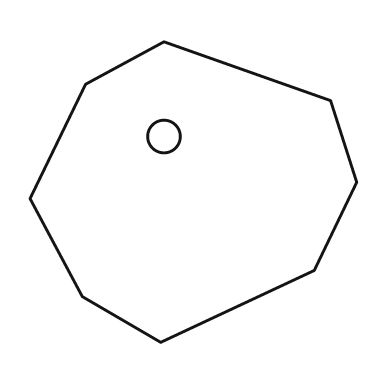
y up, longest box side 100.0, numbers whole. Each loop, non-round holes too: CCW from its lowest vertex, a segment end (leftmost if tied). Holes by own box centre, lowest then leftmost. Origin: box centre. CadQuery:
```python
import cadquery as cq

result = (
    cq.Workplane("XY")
    .moveTo(-10.0, -46.0)
    .lineTo(37.0, -24.0)
    .lineTo(50.0, 3.0)
    .lineTo(42.0, 28.0)
    .lineTo(-9.0, 46.0)
    .lineTo(-33.0, 33.0)
    .lineTo(-50.0, -2.0)
    .lineTo(-34.0, -32.0)
    .close()
    .moveTo(-9.0, 17.0)
    .circle(5.0)
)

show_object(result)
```